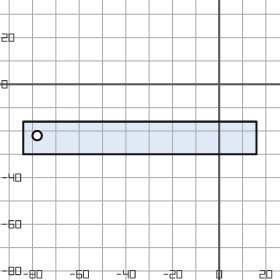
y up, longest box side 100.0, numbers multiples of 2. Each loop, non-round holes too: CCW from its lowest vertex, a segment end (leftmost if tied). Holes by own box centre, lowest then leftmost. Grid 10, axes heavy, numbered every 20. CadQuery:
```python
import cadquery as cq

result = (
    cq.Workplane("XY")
    .moveTo(-84.0, -30.0)
    .lineTo(16.0, -30.0)
    .lineTo(16.0, -16.0)
    .lineTo(-84.0, -16.0)
    .close()
    .moveTo(-78.0, -22.0)
    .circle(2.0)
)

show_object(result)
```